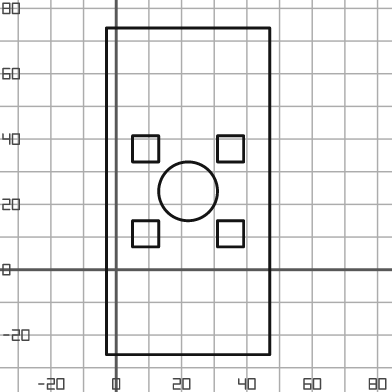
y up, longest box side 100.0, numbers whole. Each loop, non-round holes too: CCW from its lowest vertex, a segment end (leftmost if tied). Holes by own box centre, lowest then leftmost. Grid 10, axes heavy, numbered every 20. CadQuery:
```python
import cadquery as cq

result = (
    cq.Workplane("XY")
    .moveTo(-3.0, -26.0)
    .lineTo(47.0, -26.0)
    .lineTo(47.0, 74.0)
    .lineTo(-3.0, 74.0)
    .close()
    .moveTo(5.0, 7.0)
    .lineTo(13.0, 7.0)
    .lineTo(13.0, 15.0)
    .lineTo(5.0, 15.0)
    .close()
    .moveTo(31.0, 7.0)
    .lineTo(39.0, 7.0)
    .lineTo(39.0, 15.0)
    .lineTo(31.0, 15.0)
    .close()
    .moveTo(22.0, 24.0)
    .circle(9.0)
    .moveTo(5.0, 33.0)
    .lineTo(13.0, 33.0)
    .lineTo(13.0, 41.0)
    .lineTo(5.0, 41.0)
    .close()
    .moveTo(31.0, 33.0)
    .lineTo(39.0, 33.0)
    .lineTo(39.0, 41.0)
    .lineTo(31.0, 41.0)
    .close()
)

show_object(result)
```